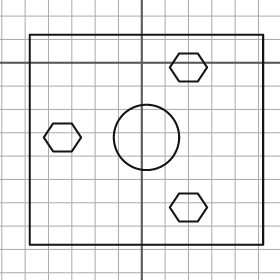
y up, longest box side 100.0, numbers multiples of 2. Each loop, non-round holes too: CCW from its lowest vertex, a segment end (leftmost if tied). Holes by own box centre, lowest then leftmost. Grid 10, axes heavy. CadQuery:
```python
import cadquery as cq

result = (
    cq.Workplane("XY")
    .moveTo(-48.0, -78.0)
    .lineTo(52.0, -78.0)
    .lineTo(52.0, 12.0)
    .lineTo(-48.0, 12.0)
    .close()
    .moveTo(16.0, -68.0)
    .lineTo(24.0, -68.0)
    .lineTo(28.0, -62.0)
    .lineTo(24.0, -56.0)
    .lineTo(16.0, -56.0)
    .lineTo(12.0, -62.0)
    .close()
    .moveTo(-38.0, -38.0)
    .lineTo(-30.0, -38.0)
    .lineTo(-26.0, -32.0)
    .lineTo(-30.0, -26.0)
    .lineTo(-38.0, -26.0)
    .lineTo(-42.0, -32.0)
    .close()
    .moveTo(2.0, -32.0)
    .circle(14.0)
    .moveTo(16.0, -8.0)
    .lineTo(24.0, -8.0)
    .lineTo(28.0, -2.0)
    .lineTo(24.0, 4.0)
    .lineTo(16.0, 4.0)
    .lineTo(12.0, -2.0)
    .close()
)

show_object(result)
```